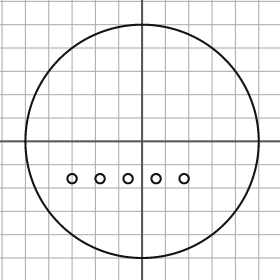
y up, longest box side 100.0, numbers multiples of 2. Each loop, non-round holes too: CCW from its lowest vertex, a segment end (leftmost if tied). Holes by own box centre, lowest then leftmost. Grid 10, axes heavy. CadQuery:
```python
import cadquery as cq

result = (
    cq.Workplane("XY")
    .moveTo(0.0, 0.0)
    .circle(50.0)
    .moveTo(-30.0, -16.0)
    .circle(2.0)
    .moveTo(-18.0, -16.0)
    .circle(2.0)
    .moveTo(-6.0, -16.0)
    .circle(2.0)
    .moveTo(6.0, -16.0)
    .circle(2.0)
    .moveTo(18.0, -16.0)
    .circle(2.0)
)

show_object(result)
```